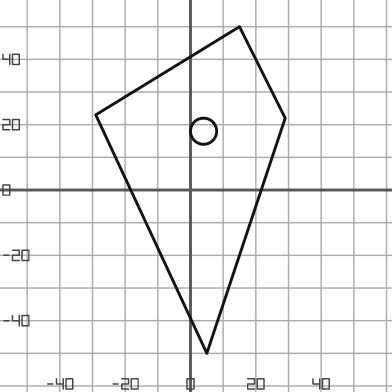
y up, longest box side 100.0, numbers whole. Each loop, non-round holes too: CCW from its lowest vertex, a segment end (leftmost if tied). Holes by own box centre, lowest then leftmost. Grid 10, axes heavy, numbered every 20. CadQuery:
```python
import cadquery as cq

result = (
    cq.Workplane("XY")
    .moveTo(5.0, -50.0)
    .lineTo(29.0, 22.0)
    .lineTo(15.0, 50.0)
    .lineTo(-29.0, 23.0)
    .close()
    .moveTo(4.0, 18.0)
    .circle(4.0)
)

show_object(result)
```